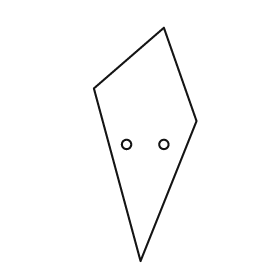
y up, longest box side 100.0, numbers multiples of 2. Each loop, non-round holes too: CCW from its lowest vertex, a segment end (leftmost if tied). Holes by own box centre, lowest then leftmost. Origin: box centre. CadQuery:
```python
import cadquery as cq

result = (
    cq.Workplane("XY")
    .moveTo(-2.0, -50.0)
    .lineTo(22.0, 10.0)
    .lineTo(8.0, 50.0)
    .lineTo(-22.0, 24.0)
    .close()
    .moveTo(-8.0, 0.0)
    .circle(2.0)
    .moveTo(8.0, 0.0)
    .circle(2.0)
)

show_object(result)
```